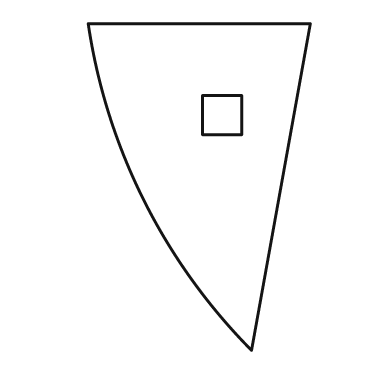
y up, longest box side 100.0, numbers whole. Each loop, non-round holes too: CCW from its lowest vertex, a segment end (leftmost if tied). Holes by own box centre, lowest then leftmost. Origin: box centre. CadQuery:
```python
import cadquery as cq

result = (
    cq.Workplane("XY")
    .moveTo(16.0, -50.0)
    .lineTo(34.0, 50.0)
    .lineTo(-34.0, 50.0)
    .threePointArc((-17.0, -4.0), (16.0, -50.0))
    .close()
    .moveTo(1.0, 16.0)
    .lineTo(13.0, 16.0)
    .lineTo(13.0, 28.0)
    .lineTo(1.0, 28.0)
    .close()
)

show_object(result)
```